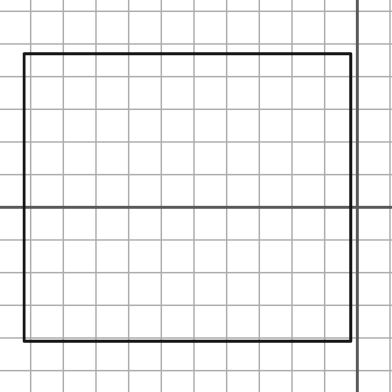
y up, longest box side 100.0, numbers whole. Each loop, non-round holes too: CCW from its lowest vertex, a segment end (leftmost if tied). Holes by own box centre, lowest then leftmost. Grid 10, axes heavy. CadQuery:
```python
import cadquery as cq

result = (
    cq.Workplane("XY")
    .moveTo(-102.0, -41.0)
    .lineTo(-2.0, -41.0)
    .lineTo(-2.0, 47.0)
    .lineTo(-102.0, 47.0)
    .close()
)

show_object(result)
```